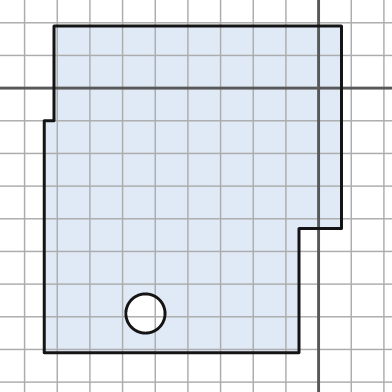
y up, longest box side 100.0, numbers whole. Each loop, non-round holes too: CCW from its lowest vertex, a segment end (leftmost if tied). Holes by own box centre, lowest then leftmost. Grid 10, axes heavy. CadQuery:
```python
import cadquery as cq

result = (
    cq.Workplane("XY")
    .moveTo(-84.0, -81.0)
    .lineTo(-6.0, -81.0)
    .lineTo(-6.0, -43.0)
    .lineTo(7.0, -43.0)
    .lineTo(7.0, 19.0)
    .lineTo(-81.0, 19.0)
    .lineTo(-81.0, -10.0)
    .lineTo(-84.0, -10.0)
    .close()
    .moveTo(-53.0, -69.0)
    .circle(6.0)
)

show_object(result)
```